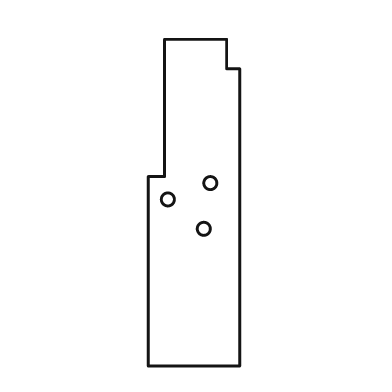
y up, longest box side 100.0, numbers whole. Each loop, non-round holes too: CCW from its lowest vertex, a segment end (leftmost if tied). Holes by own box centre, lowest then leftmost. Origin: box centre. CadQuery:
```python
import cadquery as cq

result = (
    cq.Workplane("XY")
    .moveTo(-14.0, -50.0)
    .lineTo(14.0, -50.0)
    .lineTo(14.0, 41.0)
    .lineTo(10.0, 41.0)
    .lineTo(10.0, 50.0)
    .lineTo(-9.0, 50.0)
    .lineTo(-9.0, 8.0)
    .lineTo(-14.0, 8.0)
    .close()
    .moveTo(3.0, -8.0)
    .circle(2.0)
    .moveTo(-8.0, 1.0)
    .circle(2.0)
    .moveTo(5.0, 6.0)
    .circle(2.0)
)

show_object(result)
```